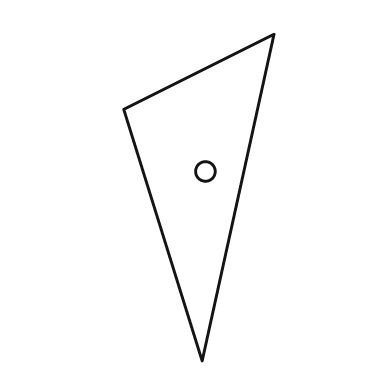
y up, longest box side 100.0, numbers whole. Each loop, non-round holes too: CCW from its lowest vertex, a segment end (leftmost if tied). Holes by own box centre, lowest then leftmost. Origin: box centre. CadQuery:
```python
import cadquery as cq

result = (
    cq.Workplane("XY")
    .moveTo(1.0, -50.0)
    .lineTo(23.0, 50.0)
    .lineTo(-23.0, 27.0)
    .close()
    .moveTo(2.0, 8.0)
    .circle(3.0)
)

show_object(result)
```